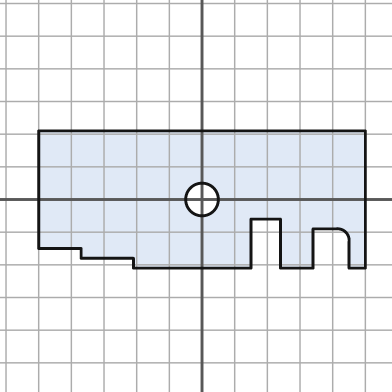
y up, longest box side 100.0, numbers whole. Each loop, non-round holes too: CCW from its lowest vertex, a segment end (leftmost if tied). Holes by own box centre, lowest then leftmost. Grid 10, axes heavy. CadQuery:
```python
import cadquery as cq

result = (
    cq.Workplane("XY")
    .moveTo(-21.0, -21.0)
    .lineTo(15.0, -21.0)
    .lineTo(15.0, -6.0)
    .lineTo(24.0, -6.0)
    .lineTo(24.0, -21.0)
    .lineTo(34.0, -21.0)
    .lineTo(34.0, -9.0)
    .lineTo(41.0, -9.0)
    .threePointArc((44.0, -10.0), (45.0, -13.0))
    .lineTo(45.0, -21.0)
    .lineTo(50.0, -21.0)
    .lineTo(50.0, 21.0)
    .lineTo(-50.0, 21.0)
    .lineTo(-50.0, -15.0)
    .lineTo(-37.0, -15.0)
    .lineTo(-37.0, -18.0)
    .lineTo(-21.0, -18.0)
    .close()
    .moveTo(0.0, 0.0)
    .circle(5.0)
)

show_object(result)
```